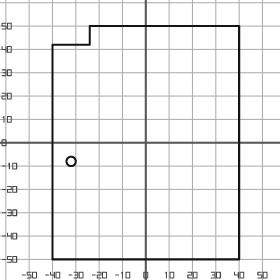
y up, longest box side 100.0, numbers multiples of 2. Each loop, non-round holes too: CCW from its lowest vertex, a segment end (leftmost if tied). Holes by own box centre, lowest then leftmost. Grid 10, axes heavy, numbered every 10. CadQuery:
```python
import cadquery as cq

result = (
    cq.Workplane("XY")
    .moveTo(-40.0, -50.0)
    .lineTo(40.0, -50.0)
    .lineTo(40.0, 50.0)
    .lineTo(-24.0, 50.0)
    .lineTo(-24.0, 42.0)
    .lineTo(-40.0, 42.0)
    .close()
    .moveTo(-32.0, -8.0)
    .circle(2.0)
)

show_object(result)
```